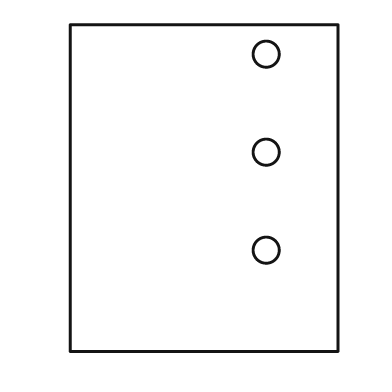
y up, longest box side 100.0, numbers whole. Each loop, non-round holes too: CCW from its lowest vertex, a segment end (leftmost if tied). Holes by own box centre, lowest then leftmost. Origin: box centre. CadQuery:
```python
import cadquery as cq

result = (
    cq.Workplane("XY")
    .moveTo(-41.0, -50.0)
    .lineTo(41.0, -50.0)
    .lineTo(41.0, 50.0)
    .lineTo(-41.0, 50.0)
    .close()
    .moveTo(19.0, -19.0)
    .circle(4.0)
    .moveTo(19.0, 11.0)
    .circle(4.0)
    .moveTo(19.0, 41.0)
    .circle(4.0)
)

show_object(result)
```